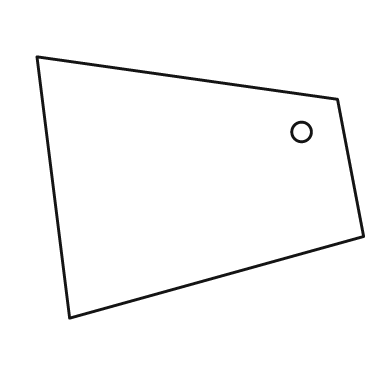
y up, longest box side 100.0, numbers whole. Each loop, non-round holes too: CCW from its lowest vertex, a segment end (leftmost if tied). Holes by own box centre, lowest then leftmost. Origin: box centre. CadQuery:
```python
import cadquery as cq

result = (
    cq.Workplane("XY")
    .moveTo(-40.0, -40.0)
    .lineTo(50.0, -15.0)
    .lineTo(42.0, 27.0)
    .lineTo(-50.0, 40.0)
    .close()
    .moveTo(31.0, 17.0)
    .circle(3.0)
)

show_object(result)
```